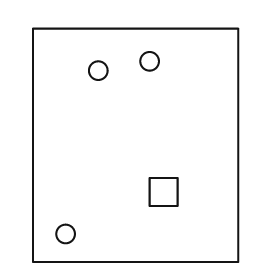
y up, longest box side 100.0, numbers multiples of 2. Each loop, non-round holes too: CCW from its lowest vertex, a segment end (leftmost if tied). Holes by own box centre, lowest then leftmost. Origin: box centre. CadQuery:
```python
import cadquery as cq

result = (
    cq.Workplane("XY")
    .moveTo(-44.0, -50.0)
    .lineTo(44.0, -50.0)
    .lineTo(44.0, 50.0)
    .lineTo(-44.0, 50.0)
    .close()
    .moveTo(-30.0, -38.0)
    .circle(4.0)
    .moveTo(6.0, -26.0)
    .lineTo(18.0, -26.0)
    .lineTo(18.0, -14.0)
    .lineTo(6.0, -14.0)
    .close()
    .moveTo(-16.0, 32.0)
    .circle(4.0)
    .moveTo(6.0, 36.0)
    .circle(4.0)
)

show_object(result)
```